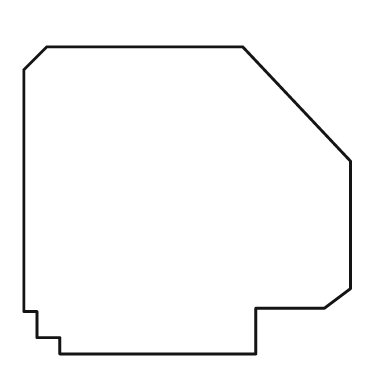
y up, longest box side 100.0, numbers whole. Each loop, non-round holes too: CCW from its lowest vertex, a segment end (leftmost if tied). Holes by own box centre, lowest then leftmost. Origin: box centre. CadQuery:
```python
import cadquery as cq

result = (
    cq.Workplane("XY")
    .moveTo(-39.0, -47.0)
    .lineTo(21.0, -47.0)
    .lineTo(21.0, -33.0)
    .lineTo(42.0, -33.0)
    .lineTo(50.0, -27.0)
    .lineTo(50.0, 12.0)
    .lineTo(17.0, 47.0)
    .lineTo(-43.0, 47.0)
    .lineTo(-50.0, 40.0)
    .lineTo(-50.0, -34.0)
    .lineTo(-46.0, -34.0)
    .lineTo(-46.0, -42.0)
    .lineTo(-39.0, -42.0)
    .close()
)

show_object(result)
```